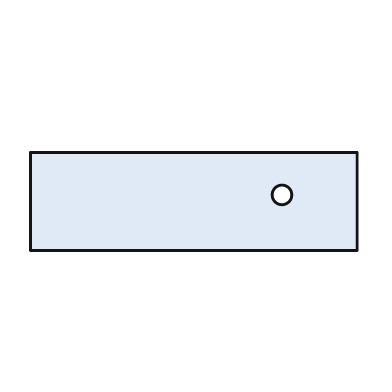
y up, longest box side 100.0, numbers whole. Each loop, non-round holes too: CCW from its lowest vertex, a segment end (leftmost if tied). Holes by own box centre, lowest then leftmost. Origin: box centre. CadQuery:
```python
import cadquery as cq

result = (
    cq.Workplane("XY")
    .moveTo(-50.0, -15.0)
    .lineTo(50.0, -15.0)
    .lineTo(50.0, 15.0)
    .lineTo(-50.0, 15.0)
    .close()
    .moveTo(27.0, 2.0)
    .circle(3.0)
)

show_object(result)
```